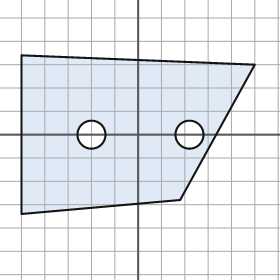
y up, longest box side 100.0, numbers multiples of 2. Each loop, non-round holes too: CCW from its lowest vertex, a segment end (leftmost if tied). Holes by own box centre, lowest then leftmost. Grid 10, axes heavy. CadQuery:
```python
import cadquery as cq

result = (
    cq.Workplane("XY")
    .moveTo(-50.0, -34.0)
    .lineTo(18.0, -28.0)
    .lineTo(50.0, 30.0)
    .lineTo(-50.0, 34.0)
    .close()
    .moveTo(-20.0, 0.0)
    .circle(6.0)
    .moveTo(22.0, 0.0)
    .circle(6.0)
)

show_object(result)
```